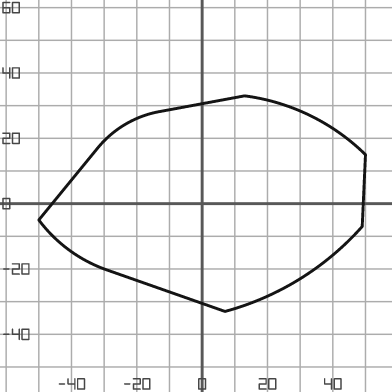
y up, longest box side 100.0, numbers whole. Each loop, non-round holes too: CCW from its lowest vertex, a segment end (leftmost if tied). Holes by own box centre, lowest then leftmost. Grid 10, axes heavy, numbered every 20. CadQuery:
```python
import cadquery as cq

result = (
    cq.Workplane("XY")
    .moveTo(7.0, -33.0)
    .threePointArc((30.0, -23.0), (49.0, -7.0))
    .lineTo(50.0, 15.0)
    .threePointArc((33.0, 27.0), (13.0, 33.0))
    .lineTo(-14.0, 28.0)
    .threePointArc((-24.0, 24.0), (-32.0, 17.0))
    .lineTo(-50.0, -5.0)
    .threePointArc((-41.0, -14.0), (-30.0, -20.0))
    .close()
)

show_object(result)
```